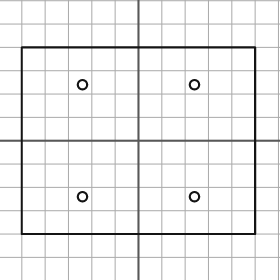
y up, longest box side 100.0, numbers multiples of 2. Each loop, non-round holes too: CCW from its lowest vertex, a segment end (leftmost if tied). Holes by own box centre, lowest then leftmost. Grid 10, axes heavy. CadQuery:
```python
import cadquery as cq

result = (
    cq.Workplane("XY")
    .moveTo(-50.0, -40.0)
    .lineTo(50.0, -40.0)
    .lineTo(50.0, 40.0)
    .lineTo(-50.0, 40.0)
    .close()
    .moveTo(-24.0, -24.0)
    .circle(2.0)
    .moveTo(24.0, -24.0)
    .circle(2.0)
    .moveTo(-24.0, 24.0)
    .circle(2.0)
    .moveTo(24.0, 24.0)
    .circle(2.0)
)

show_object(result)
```